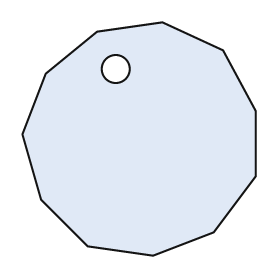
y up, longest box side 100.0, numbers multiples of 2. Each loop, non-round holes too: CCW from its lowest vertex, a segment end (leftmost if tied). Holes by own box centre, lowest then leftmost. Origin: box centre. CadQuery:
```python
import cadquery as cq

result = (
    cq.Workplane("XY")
    .moveTo(6.0, -50.0)
    .lineTo(32.0, -40.0)
    .lineTo(50.0, -16.0)
    .lineTo(50.0, 12.0)
    .lineTo(36.0, 38.0)
    .lineTo(10.0, 50.0)
    .lineTo(-18.0, 46.0)
    .lineTo(-40.0, 28.0)
    .lineTo(-50.0, 2.0)
    .lineTo(-42.0, -26.0)
    .lineTo(-22.0, -46.0)
    .close()
    .moveTo(-10.0, 30.0)
    .circle(6.0)
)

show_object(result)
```